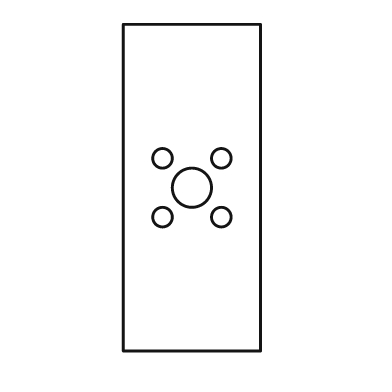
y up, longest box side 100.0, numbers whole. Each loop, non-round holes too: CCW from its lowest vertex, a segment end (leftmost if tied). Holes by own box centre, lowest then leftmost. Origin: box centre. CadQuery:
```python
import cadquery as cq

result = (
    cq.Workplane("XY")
    .moveTo(-21.0, -50.0)
    .lineTo(21.0, -50.0)
    .lineTo(21.0, 50.0)
    .lineTo(-21.0, 50.0)
    .close()
    .moveTo(-9.0, -9.0)
    .circle(3.0)
    .moveTo(9.0, -9.0)
    .circle(3.0)
    .moveTo(0.0, 0.0)
    .circle(6.0)
    .moveTo(-9.0, 9.0)
    .circle(3.0)
    .moveTo(9.0, 9.0)
    .circle(3.0)
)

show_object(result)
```